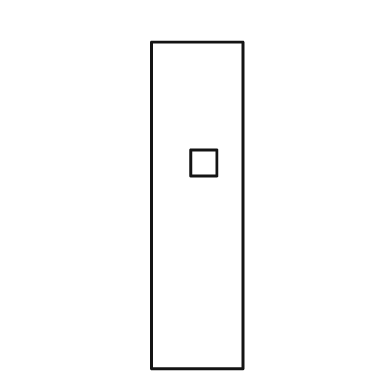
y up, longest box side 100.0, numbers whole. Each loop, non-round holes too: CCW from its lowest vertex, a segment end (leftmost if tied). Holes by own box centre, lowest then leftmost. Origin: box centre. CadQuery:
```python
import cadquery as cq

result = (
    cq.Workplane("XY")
    .moveTo(-14.0, -50.0)
    .lineTo(14.0, -50.0)
    .lineTo(14.0, 50.0)
    .lineTo(-14.0, 50.0)
    .close()
    .moveTo(-2.0, 9.0)
    .lineTo(6.0, 9.0)
    .lineTo(6.0, 17.0)
    .lineTo(-2.0, 17.0)
    .close()
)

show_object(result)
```